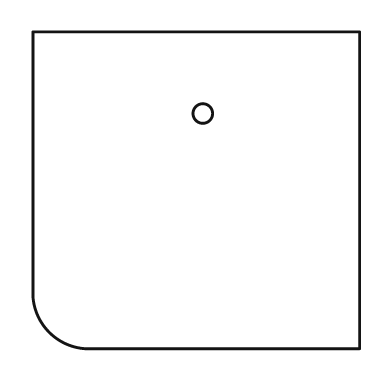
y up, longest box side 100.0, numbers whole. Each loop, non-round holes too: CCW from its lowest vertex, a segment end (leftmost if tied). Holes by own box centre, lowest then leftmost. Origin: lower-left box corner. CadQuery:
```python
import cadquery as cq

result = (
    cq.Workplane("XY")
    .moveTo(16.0, 0.0)
    .lineTo(100.0, 0.0)
    .lineTo(100.0, 97.0)
    .lineTo(0.0, 97.0)
    .lineTo(0.0, 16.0)
    .threePointArc((5.0, 5.0), (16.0, 0.0))
    .close()
    .moveTo(52.0, 72.0)
    .circle(3.0)
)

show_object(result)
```